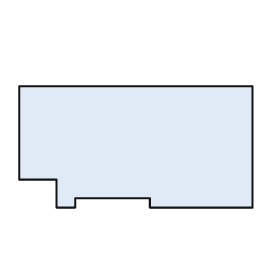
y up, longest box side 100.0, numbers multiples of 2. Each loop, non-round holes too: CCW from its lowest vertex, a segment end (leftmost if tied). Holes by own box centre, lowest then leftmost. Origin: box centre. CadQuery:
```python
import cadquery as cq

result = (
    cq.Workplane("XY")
    .moveTo(-34.0, -26.0)
    .lineTo(-26.0, -26.0)
    .lineTo(-26.0, -22.0)
    .lineTo(6.0, -22.0)
    .lineTo(6.0, -26.0)
    .lineTo(50.0, -26.0)
    .lineTo(50.0, 26.0)
    .lineTo(-50.0, 26.0)
    .lineTo(-50.0, -14.0)
    .lineTo(-34.0, -14.0)
    .close()
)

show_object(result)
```